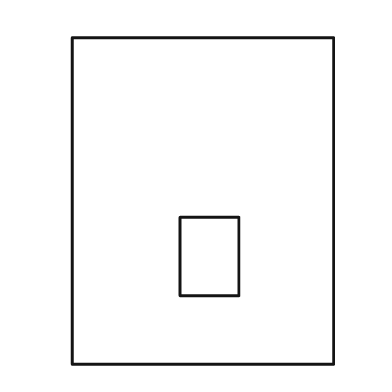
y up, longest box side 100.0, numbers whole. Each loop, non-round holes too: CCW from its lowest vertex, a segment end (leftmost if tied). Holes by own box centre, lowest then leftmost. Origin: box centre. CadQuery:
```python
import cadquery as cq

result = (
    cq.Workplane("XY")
    .moveTo(-40.0, -50.0)
    .lineTo(40.0, -50.0)
    .lineTo(40.0, 50.0)
    .lineTo(-40.0, 50.0)
    .close()
    .moveTo(-7.0, -29.0)
    .lineTo(11.0, -29.0)
    .lineTo(11.0, -5.0)
    .lineTo(-7.0, -5.0)
    .close()
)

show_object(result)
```